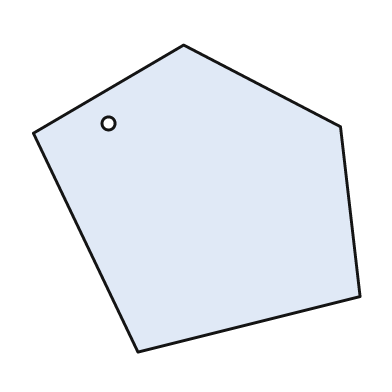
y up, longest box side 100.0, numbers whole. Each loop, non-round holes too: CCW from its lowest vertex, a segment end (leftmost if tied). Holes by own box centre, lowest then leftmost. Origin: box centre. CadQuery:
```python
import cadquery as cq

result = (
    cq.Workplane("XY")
    .moveTo(-18.0, -47.0)
    .lineTo(50.0, -30.0)
    .lineTo(44.0, 22.0)
    .lineTo(-4.0, 47.0)
    .lineTo(-50.0, 20.0)
    .close()
    .moveTo(-27.0, 23.0)
    .circle(2.0)
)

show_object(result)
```